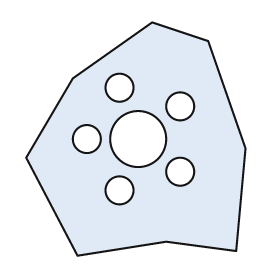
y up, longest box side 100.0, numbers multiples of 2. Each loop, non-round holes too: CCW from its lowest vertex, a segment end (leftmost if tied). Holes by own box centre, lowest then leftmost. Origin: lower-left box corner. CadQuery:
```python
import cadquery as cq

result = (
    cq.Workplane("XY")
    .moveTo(22.0, 0.0)
    .lineTo(60.0, 6.0)
    .lineTo(90.0, 2.0)
    .lineTo(94.0, 46.0)
    .lineTo(78.0, 92.0)
    .lineTo(54.0, 100.0)
    .lineTo(20.0, 76.0)
    .lineTo(0.0, 42.0)
    .close()
    .moveTo(40.0, 28.0)
    .circle(6.0)
    .moveTo(66.0, 36.0)
    .circle(6.0)
    .moveTo(26.0, 50.0)
    .circle(6.0)
    .moveTo(48.0, 50.0)
    .circle(12.0)
    .moveTo(66.0, 64.0)
    .circle(6.0)
    .moveTo(40.0, 72.0)
    .circle(6.0)
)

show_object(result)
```